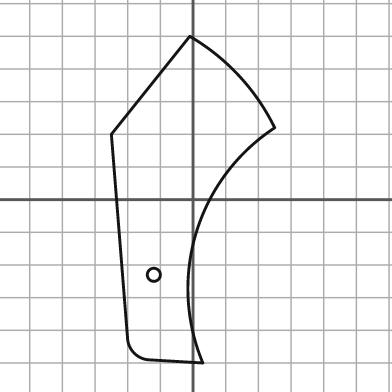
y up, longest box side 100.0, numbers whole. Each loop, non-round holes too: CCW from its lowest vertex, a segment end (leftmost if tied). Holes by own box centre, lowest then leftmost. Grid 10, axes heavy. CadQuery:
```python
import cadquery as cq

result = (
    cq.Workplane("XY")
    .moveTo(3.0, -50.0)
    .threePointArc((1.0, -10.0), (25.0, 22.0))
    .threePointArc((14.0, 38.0), (-1.0, 50.0))
    .lineTo(-25.0, 20.0)
    .lineTo(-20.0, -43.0)
    .threePointArc((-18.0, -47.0), (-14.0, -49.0))
    .close()
    .moveTo(-12.0, -23.0)
    .circle(2.0)
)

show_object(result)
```